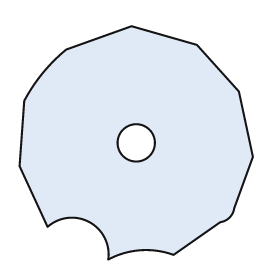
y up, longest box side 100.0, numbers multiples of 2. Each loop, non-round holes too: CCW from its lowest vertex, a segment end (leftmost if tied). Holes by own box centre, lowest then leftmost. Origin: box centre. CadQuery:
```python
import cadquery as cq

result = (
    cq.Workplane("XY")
    .moveTo(-12.0, -50.0)
    .threePointArc((2.0, -46.0), (16.0, -48.0))
    .lineTo(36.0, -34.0)
    .threePointArc((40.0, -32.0), (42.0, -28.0))
    .lineTo(50.0, -6.0)
    .lineTo(44.0, 22.0)
    .lineTo(26.0, 42.0)
    .lineTo(-2.0, 50.0)
    .lineTo(-30.0, 40.0)
    .threePointArc((-40.0, 30.0), (-48.0, 18.0))
    .lineTo(-50.0, -10.0)
    .lineTo(-38.0, -36.0)
    .threePointArc((-20.0, -34.0), (-12.0, -50.0))
    .close()
    .moveTo(0.0, 0.0)
    .circle(8.0)
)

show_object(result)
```